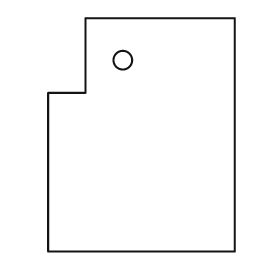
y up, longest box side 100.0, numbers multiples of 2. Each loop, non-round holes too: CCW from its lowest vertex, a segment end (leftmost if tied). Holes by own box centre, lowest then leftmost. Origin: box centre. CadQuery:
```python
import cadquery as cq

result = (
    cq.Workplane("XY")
    .moveTo(-40.0, -50.0)
    .lineTo(40.0, -50.0)
    .lineTo(40.0, 50.0)
    .lineTo(-24.0, 50.0)
    .lineTo(-24.0, 18.0)
    .lineTo(-40.0, 18.0)
    .close()
    .moveTo(-8.0, 32.0)
    .circle(4.0)
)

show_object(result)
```